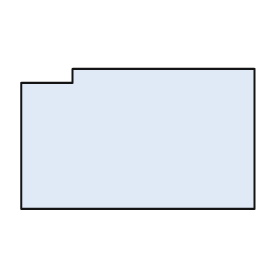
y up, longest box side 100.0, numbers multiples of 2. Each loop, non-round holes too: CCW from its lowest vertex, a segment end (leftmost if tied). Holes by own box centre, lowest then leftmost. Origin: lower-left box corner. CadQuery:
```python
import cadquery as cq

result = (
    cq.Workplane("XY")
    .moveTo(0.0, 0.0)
    .lineTo(100.0, 0.0)
    .lineTo(100.0, 60.0)
    .lineTo(22.0, 60.0)
    .lineTo(22.0, 54.0)
    .lineTo(0.0, 54.0)
    .close()
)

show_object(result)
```